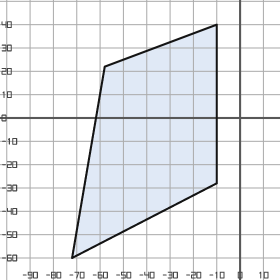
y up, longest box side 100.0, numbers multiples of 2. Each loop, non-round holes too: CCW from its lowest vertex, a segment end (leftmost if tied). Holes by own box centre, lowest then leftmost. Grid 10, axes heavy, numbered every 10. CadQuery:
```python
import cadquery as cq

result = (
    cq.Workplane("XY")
    .moveTo(-72.0, -60.0)
    .lineTo(-10.0, -28.0)
    .lineTo(-10.0, 40.0)
    .lineTo(-58.0, 22.0)
    .close()
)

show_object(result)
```